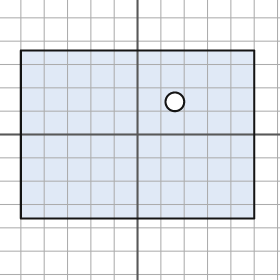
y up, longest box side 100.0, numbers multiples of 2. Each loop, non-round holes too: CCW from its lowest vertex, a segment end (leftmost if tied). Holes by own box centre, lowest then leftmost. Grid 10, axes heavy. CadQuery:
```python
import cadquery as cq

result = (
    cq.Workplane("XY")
    .moveTo(-50.0, -36.0)
    .lineTo(50.0, -36.0)
    .lineTo(50.0, 36.0)
    .lineTo(-50.0, 36.0)
    .close()
    .moveTo(16.0, 14.0)
    .circle(4.0)
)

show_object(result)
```